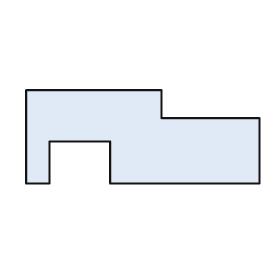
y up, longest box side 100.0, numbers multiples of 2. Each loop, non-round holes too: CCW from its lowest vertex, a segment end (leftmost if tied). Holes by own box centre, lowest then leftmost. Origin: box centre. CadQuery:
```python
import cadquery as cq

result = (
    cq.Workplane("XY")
    .moveTo(-50.0, -20.0)
    .lineTo(-40.0, -20.0)
    .lineTo(-40.0, -2.0)
    .lineTo(-14.0, -2.0)
    .lineTo(-14.0, -20.0)
    .lineTo(50.0, -20.0)
    .lineTo(50.0, 8.0)
    .lineTo(8.0, 8.0)
    .lineTo(8.0, 20.0)
    .lineTo(-50.0, 20.0)
    .close()
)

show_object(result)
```